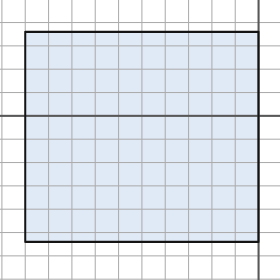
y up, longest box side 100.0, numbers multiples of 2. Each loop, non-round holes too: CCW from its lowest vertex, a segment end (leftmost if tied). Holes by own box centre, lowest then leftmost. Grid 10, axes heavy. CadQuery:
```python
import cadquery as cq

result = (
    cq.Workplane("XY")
    .moveTo(-100.0, -54.0)
    .lineTo(0.0, -54.0)
    .lineTo(0.0, 36.0)
    .lineTo(-100.0, 36.0)
    .close()
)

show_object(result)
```